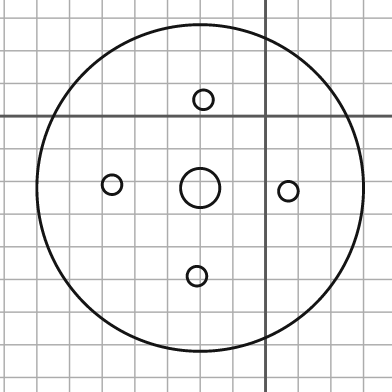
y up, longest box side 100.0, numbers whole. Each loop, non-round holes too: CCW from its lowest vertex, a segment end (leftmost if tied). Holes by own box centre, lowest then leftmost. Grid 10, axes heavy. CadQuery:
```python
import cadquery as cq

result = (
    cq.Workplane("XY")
    .moveTo(-20.0, -22.0)
    .circle(50.0)
    .moveTo(-21.0, -49.0)
    .circle(3.0)
    .moveTo(7.0, -23.0)
    .circle(3.0)
    .moveTo(-20.0, -22.0)
    .circle(6.0)
    .moveTo(-47.0, -21.0)
    .circle(3.0)
    .moveTo(-19.0, 5.0)
    .circle(3.0)
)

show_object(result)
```